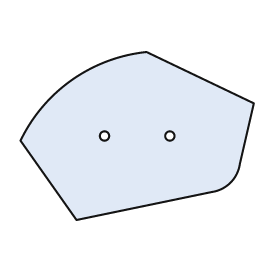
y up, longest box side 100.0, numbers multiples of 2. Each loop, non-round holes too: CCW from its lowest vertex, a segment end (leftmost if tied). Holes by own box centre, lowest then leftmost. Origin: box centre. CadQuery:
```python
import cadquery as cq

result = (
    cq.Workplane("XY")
    .moveTo(-26.0, -36.0)
    .lineTo(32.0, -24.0)
    .threePointArc((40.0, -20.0), (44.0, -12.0))
    .lineTo(50.0, 14.0)
    .lineTo(4.0, 36.0)
    .threePointArc((-28.0, 24.0), (-50.0, -2.0))
    .close()
    .moveTo(-14.0, 0.0)
    .circle(2.0)
    .moveTo(14.0, 0.0)
    .circle(2.0)
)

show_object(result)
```